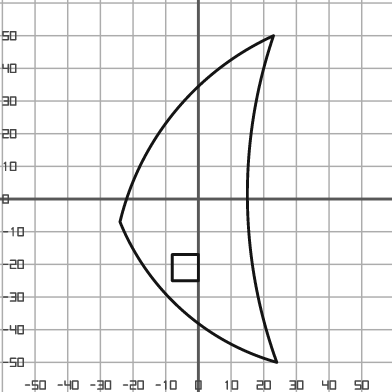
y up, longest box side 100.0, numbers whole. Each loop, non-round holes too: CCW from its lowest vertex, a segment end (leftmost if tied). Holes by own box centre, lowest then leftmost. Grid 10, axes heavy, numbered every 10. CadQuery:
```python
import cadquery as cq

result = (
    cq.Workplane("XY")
    .moveTo(24.0, -50.0)
    .threePointArc((15.0, 0.0), (23.0, 50.0))
    .threePointArc((-7.0, 27.0), (-24.0, -7.0))
    .threePointArc((-5.0, -34.0), (24.0, -50.0))
    .close()
    .moveTo(-8.0, -25.0)
    .lineTo(0.0, -25.0)
    .lineTo(0.0, -17.0)
    .lineTo(-8.0, -17.0)
    .close()
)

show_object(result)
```